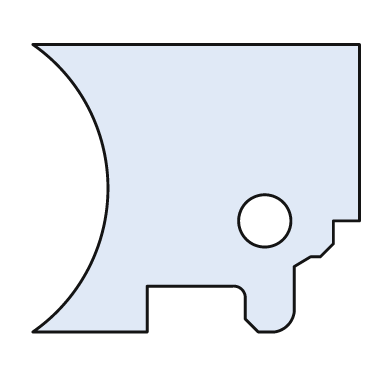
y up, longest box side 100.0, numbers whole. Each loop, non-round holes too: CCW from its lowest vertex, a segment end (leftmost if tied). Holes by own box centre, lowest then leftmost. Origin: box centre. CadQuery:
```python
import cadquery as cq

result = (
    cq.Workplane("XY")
    .moveTo(-50.0, -44.0)
    .lineTo(-15.0, -44.0)
    .lineTo(-15.0, -30.0)
    .lineTo(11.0, -30.0)
    .threePointArc((14.0, -31.0), (15.0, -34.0))
    .lineTo(15.0, -40.0)
    .lineTo(19.0, -44.0)
    .lineTo(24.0, -44.0)
    .threePointArc((28.0, -42.0), (30.0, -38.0))
    .lineTo(30.0, -24.0)
    .lineTo(35.0, -21.0)
    .lineTo(38.0, -21.0)
    .lineTo(42.0, -17.0)
    .lineTo(42.0, -10.0)
    .lineTo(50.0, -10.0)
    .lineTo(50.0, 44.0)
    .lineTo(-50.0, 44.0)
    .threePointArc((-27.0, 0.0), (-50.0, -44.0))
    .close()
    .moveTo(21.0, -10.0)
    .circle(8.0)
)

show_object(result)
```